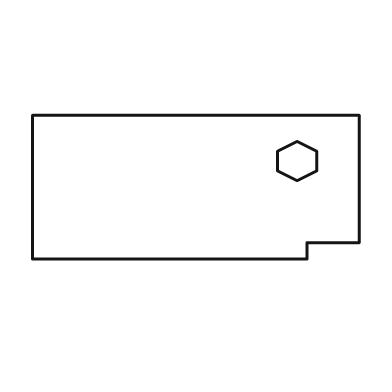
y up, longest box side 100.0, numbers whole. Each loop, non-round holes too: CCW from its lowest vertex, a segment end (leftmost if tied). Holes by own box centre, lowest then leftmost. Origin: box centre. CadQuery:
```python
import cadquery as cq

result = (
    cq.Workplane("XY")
    .moveTo(-50.0, -22.0)
    .lineTo(34.0, -22.0)
    .lineTo(34.0, -17.0)
    .lineTo(50.0, -17.0)
    .lineTo(50.0, 22.0)
    .lineTo(-50.0, 22.0)
    .close()
    .moveTo(31.0, 2.0)
    .lineTo(37.0, 5.0)
    .lineTo(37.0, 11.0)
    .lineTo(31.0, 14.0)
    .lineTo(25.0, 11.0)
    .lineTo(25.0, 5.0)
    .close()
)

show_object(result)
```